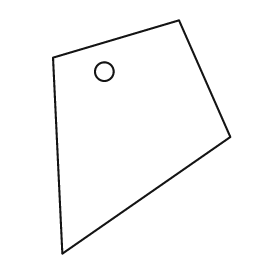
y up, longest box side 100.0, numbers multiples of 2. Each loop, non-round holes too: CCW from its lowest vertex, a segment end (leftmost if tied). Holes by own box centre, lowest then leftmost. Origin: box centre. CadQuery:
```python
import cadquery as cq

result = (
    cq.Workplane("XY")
    .moveTo(-34.0, -50.0)
    .lineTo(38.0, 0.0)
    .lineTo(16.0, 50.0)
    .lineTo(-38.0, 34.0)
    .close()
    .moveTo(-16.0, 28.0)
    .circle(4.0)
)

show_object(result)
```